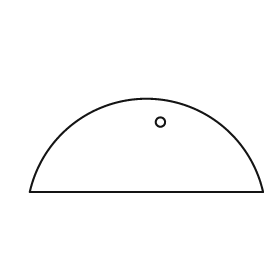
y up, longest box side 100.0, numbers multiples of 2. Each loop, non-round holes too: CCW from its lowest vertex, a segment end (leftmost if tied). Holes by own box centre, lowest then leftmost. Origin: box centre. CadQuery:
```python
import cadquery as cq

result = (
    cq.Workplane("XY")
    .moveTo(-50.0, -20.0)
    .lineTo(50.0, -20.0)
    .threePointArc((0.0, 20.0), (-50.0, -20.0))
    .close()
    .moveTo(6.0, 10.0)
    .circle(2.0)
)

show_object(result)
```